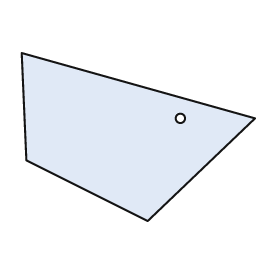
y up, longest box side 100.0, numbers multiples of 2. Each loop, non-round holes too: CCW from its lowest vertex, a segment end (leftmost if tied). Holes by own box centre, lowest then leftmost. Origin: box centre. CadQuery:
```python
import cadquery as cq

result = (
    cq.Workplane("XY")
    .moveTo(4.0, -36.0)
    .lineTo(50.0, 8.0)
    .lineTo(-50.0, 36.0)
    .lineTo(-48.0, -10.0)
    .close()
    .moveTo(18.0, 8.0)
    .circle(2.0)
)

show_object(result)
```